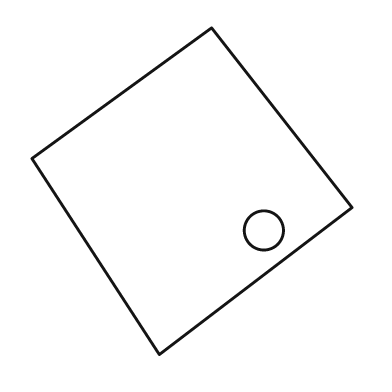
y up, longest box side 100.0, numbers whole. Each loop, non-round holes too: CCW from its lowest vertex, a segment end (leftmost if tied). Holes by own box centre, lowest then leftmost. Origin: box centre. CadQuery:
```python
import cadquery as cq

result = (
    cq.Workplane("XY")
    .moveTo(-10.0, -50.0)
    .lineTo(49.0, -5.0)
    .lineTo(6.0, 50.0)
    .lineTo(-49.0, 10.0)
    .close()
    .moveTo(22.0, -12.0)
    .circle(6.0)
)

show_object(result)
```